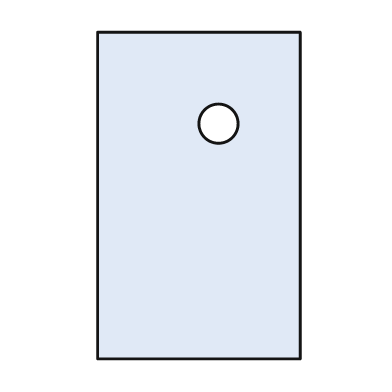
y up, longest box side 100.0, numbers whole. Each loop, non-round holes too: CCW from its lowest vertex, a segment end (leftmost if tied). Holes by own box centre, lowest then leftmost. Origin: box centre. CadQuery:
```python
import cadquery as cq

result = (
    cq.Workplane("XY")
    .moveTo(-31.0, -50.0)
    .lineTo(31.0, -50.0)
    .lineTo(31.0, 50.0)
    .lineTo(-31.0, 50.0)
    .close()
    .moveTo(6.0, 22.0)
    .circle(6.0)
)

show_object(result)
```